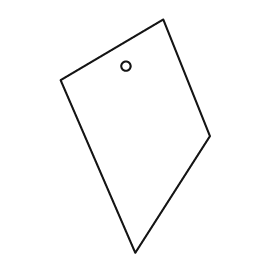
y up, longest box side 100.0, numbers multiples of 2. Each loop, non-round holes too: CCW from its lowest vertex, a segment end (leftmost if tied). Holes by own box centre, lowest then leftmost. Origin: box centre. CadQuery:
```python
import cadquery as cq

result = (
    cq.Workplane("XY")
    .moveTo(0.0, -50.0)
    .lineTo(32.0, 0.0)
    .lineTo(12.0, 50.0)
    .lineTo(-32.0, 24.0)
    .close()
    .moveTo(-4.0, 30.0)
    .circle(2.0)
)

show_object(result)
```